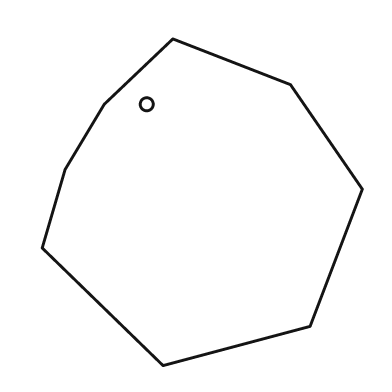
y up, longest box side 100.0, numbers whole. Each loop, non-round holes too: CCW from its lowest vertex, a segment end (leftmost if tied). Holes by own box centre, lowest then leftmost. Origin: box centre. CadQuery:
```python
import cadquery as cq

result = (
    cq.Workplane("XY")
    .moveTo(-12.0, -50.0)
    .lineTo(33.0, -38.0)
    .lineTo(49.0, 4.0)
    .lineTo(27.0, 36.0)
    .lineTo(-9.0, 50.0)
    .lineTo(-30.0, 30.0)
    .lineTo(-42.0, 10.0)
    .lineTo(-49.0, -14.0)
    .close()
    .moveTo(-17.0, 30.0)
    .circle(2.0)
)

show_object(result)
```